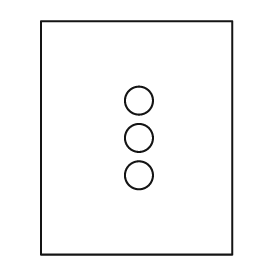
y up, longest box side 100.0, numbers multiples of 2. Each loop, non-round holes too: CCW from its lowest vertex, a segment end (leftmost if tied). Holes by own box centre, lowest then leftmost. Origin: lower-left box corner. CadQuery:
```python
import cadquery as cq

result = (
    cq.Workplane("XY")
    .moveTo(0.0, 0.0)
    .lineTo(82.0, 0.0)
    .lineTo(82.0, 100.0)
    .lineTo(0.0, 100.0)
    .close()
    .moveTo(42.0, 34.0)
    .circle(6.0)
    .moveTo(42.0, 50.0)
    .circle(6.0)
    .moveTo(42.0, 66.0)
    .circle(6.0)
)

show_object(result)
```